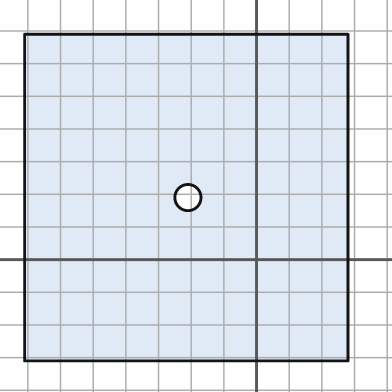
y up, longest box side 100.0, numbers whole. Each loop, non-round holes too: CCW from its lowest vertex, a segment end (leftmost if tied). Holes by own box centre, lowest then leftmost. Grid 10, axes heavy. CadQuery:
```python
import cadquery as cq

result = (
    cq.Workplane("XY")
    .moveTo(-71.0, -31.0)
    .lineTo(28.0, -31.0)
    .lineTo(28.0, 69.0)
    .lineTo(-71.0, 69.0)
    .close()
    .moveTo(-21.0, 19.0)
    .circle(4.0)
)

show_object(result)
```